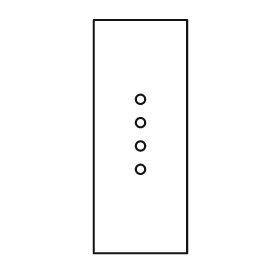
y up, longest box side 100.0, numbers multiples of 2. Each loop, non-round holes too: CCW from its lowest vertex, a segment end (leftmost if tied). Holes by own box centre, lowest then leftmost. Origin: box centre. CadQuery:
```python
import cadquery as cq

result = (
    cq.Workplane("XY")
    .moveTo(-20.0, -50.0)
    .lineTo(20.0, -50.0)
    .lineTo(20.0, 50.0)
    .lineTo(-20.0, 50.0)
    .close()
    .moveTo(0.0, -14.0)
    .circle(2.0)
    .moveTo(0.0, -4.0)
    .circle(2.0)
    .moveTo(0.0, 6.0)
    .circle(2.0)
    .moveTo(0.0, 16.0)
    .circle(2.0)
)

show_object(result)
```